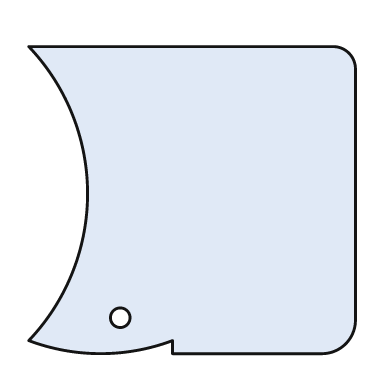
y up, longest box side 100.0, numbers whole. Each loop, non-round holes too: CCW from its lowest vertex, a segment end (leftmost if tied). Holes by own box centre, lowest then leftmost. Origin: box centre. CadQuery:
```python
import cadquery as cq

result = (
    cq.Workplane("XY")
    .moveTo(-6.0, -47.0)
    .lineTo(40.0, -47.0)
    .threePointArc((47.0, -44.0), (50.0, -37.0))
    .lineTo(50.0, 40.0)
    .threePointArc((48.0, 45.0), (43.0, 47.0))
    .lineTo(-50.0, 47.0)
    .threePointArc((-32.0, 2.0), (-50.0, -43.0))
    .threePointArc((-28.0, -47.0), (-6.0, -43.0))
    .close()
    .moveTo(-22.0, -36.0)
    .circle(3.0)
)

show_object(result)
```